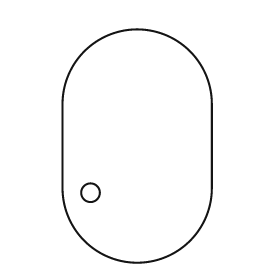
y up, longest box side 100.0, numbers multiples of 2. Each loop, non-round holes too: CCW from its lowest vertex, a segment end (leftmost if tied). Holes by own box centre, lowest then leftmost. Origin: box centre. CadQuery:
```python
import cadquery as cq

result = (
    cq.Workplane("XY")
    .moveTo(-32.0, -18.0)
    .threePointArc((0.0, -50.0), (32.0, -18.0))
    .lineTo(32.0, 18.0)
    .threePointArc((0.0, 50.0), (-32.0, 18.0))
    .close()
    .moveTo(-20.0, -20.0)
    .circle(4.0)
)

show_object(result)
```